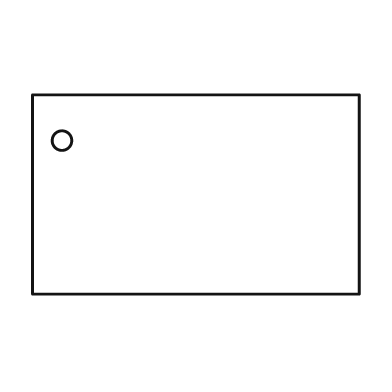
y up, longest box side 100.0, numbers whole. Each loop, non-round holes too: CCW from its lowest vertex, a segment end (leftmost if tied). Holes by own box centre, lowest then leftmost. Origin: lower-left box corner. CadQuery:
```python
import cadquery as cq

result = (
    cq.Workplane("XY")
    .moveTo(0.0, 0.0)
    .lineTo(100.0, 0.0)
    .lineTo(100.0, 61.0)
    .lineTo(0.0, 61.0)
    .close()
    .moveTo(9.0, 47.0)
    .circle(3.0)
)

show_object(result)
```